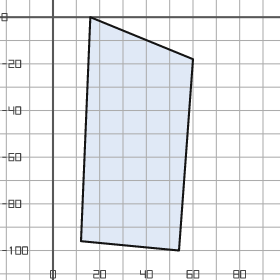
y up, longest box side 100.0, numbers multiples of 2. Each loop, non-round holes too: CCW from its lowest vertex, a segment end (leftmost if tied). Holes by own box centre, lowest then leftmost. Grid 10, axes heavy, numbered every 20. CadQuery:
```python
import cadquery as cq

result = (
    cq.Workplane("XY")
    .moveTo(54.0, -100.0)
    .lineTo(60.0, -18.0)
    .lineTo(16.0, 0.0)
    .lineTo(12.0, -96.0)
    .close()
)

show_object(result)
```